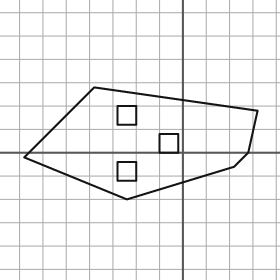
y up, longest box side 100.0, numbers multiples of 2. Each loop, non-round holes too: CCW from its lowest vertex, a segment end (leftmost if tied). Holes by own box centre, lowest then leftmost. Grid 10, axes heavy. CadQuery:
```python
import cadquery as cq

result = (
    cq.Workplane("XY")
    .moveTo(-24.0, -20.0)
    .lineTo(22.0, -6.0)
    .lineTo(28.0, 0.0)
    .lineTo(32.0, 18.0)
    .lineTo(-38.0, 28.0)
    .lineTo(-68.0, -2.0)
    .close()
    .moveTo(-28.0, -12.0)
    .lineTo(-20.0, -12.0)
    .lineTo(-20.0, -4.0)
    .lineTo(-28.0, -4.0)
    .close()
    .moveTo(-10.0, 0.0)
    .lineTo(-2.0, 0.0)
    .lineTo(-2.0, 8.0)
    .lineTo(-10.0, 8.0)
    .close()
    .moveTo(-28.0, 12.0)
    .lineTo(-20.0, 12.0)
    .lineTo(-20.0, 20.0)
    .lineTo(-28.0, 20.0)
    .close()
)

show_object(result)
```